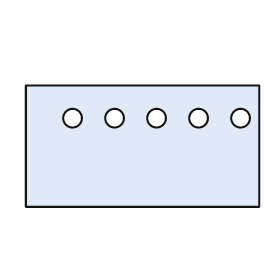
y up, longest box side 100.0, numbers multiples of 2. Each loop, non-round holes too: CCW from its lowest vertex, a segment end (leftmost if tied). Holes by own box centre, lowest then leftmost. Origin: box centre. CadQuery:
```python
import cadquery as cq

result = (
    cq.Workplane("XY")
    .moveTo(-50.0, -26.0)
    .lineTo(50.0, -26.0)
    .lineTo(50.0, 26.0)
    .lineTo(-50.0, 26.0)
    .close()
    .moveTo(-30.0, 12.0)
    .circle(4.0)
    .moveTo(-12.0, 12.0)
    .circle(4.0)
    .moveTo(6.0, 12.0)
    .circle(4.0)
    .moveTo(24.0, 12.0)
    .circle(4.0)
    .moveTo(42.0, 12.0)
    .circle(4.0)
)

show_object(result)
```